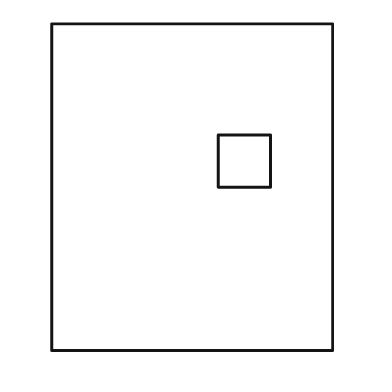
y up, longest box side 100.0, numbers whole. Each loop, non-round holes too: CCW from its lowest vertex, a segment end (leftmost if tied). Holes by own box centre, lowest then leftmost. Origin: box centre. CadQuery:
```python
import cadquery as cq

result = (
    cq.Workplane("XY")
    .moveTo(-43.0, -50.0)
    .lineTo(43.0, -50.0)
    .lineTo(43.0, 50.0)
    .lineTo(-43.0, 50.0)
    .close()
    .moveTo(8.0, 0.0)
    .lineTo(24.0, 0.0)
    .lineTo(24.0, 16.0)
    .lineTo(8.0, 16.0)
    .close()
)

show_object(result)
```